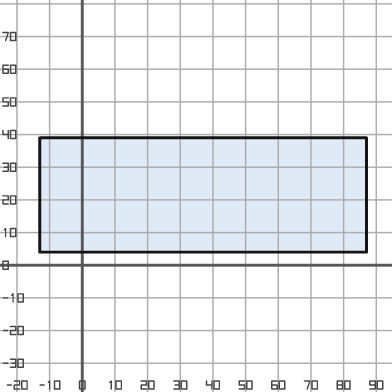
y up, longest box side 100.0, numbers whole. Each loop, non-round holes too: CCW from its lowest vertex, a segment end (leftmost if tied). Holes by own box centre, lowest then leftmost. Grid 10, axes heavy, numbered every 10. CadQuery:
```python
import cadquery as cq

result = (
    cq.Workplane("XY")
    .moveTo(-13.0, 4.0)
    .lineTo(87.0, 4.0)
    .lineTo(87.0, 39.0)
    .lineTo(-13.0, 39.0)
    .close()
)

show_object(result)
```